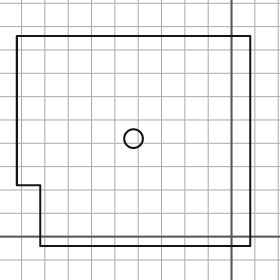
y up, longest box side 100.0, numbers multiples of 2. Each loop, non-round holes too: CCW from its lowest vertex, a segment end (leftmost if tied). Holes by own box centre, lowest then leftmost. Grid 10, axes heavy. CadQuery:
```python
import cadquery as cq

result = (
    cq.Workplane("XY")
    .moveTo(-82.0, -4.0)
    .lineTo(8.0, -4.0)
    .lineTo(8.0, 86.0)
    .lineTo(-92.0, 86.0)
    .lineTo(-92.0, 22.0)
    .lineTo(-82.0, 22.0)
    .close()
    .moveTo(-42.0, 42.0)
    .circle(4.0)
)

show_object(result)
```